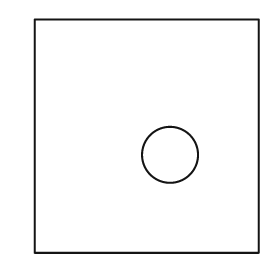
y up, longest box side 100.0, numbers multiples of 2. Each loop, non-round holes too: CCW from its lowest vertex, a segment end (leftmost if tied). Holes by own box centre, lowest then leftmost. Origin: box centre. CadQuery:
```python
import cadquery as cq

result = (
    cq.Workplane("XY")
    .moveTo(-48.0, -50.0)
    .lineTo(48.0, -50.0)
    .lineTo(48.0, 50.0)
    .lineTo(-48.0, 50.0)
    .close()
    .moveTo(10.0, -8.0)
    .circle(12.0)
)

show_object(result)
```